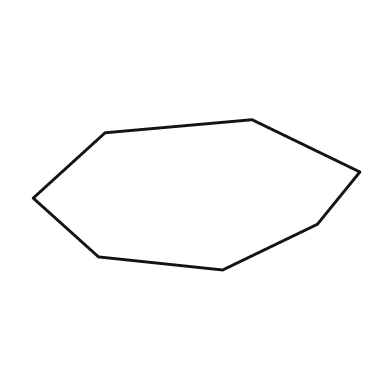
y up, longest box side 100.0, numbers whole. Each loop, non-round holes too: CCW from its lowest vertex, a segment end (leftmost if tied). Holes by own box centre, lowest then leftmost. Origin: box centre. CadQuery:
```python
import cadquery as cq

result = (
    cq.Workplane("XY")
    .moveTo(8.0, -23.0)
    .lineTo(37.0, -9.0)
    .lineTo(50.0, 7.0)
    .lineTo(17.0, 23.0)
    .lineTo(-28.0, 19.0)
    .lineTo(-50.0, -1.0)
    .lineTo(-30.0, -19.0)
    .close()
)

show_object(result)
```